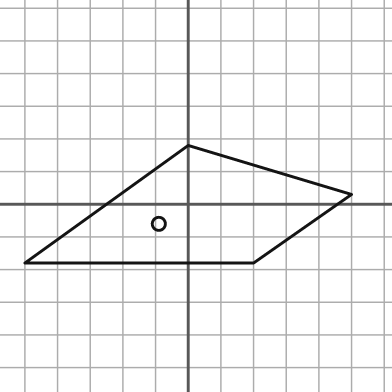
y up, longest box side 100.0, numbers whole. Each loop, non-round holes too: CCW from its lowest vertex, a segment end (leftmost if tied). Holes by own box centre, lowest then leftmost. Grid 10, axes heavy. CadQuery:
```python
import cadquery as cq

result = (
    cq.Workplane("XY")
    .moveTo(-50.0, -18.0)
    .lineTo(20.0, -18.0)
    .lineTo(50.0, 3.0)
    .lineTo(0.0, 18.0)
    .close()
    .moveTo(-9.0, -6.0)
    .circle(2.0)
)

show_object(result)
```